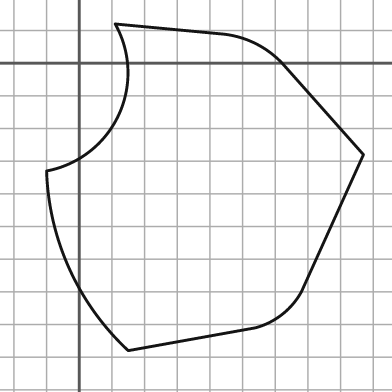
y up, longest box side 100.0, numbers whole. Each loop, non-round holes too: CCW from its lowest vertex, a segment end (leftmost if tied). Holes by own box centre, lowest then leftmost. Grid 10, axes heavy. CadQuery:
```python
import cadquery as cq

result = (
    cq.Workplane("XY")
    .moveTo(15.0, -88.0)
    .lineTo(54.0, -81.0)
    .threePointArc((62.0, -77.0), (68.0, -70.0))
    .lineTo(87.0, -28.0)
    .lineTo(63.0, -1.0)
    .threePointArc((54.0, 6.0), (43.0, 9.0))
    .lineTo(11.0, 12.0)
    .threePointArc((12.0, -16.0), (-10.0, -33.0))
    .threePointArc((-3.0, -63.0), (15.0, -88.0))
    .close()
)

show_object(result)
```